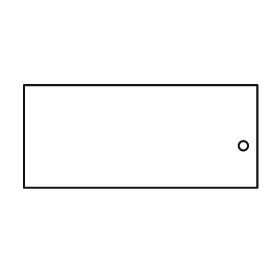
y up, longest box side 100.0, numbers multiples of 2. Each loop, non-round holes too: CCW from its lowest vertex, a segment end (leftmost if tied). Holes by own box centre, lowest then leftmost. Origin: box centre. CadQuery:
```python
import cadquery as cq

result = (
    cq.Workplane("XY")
    .moveTo(-50.0, -22.0)
    .lineTo(50.0, -22.0)
    .lineTo(50.0, 22.0)
    .lineTo(-50.0, 22.0)
    .close()
    .moveTo(44.0, -4.0)
    .circle(2.0)
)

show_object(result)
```